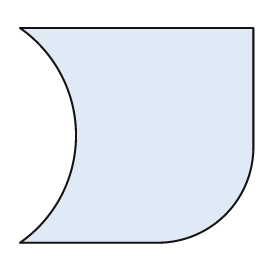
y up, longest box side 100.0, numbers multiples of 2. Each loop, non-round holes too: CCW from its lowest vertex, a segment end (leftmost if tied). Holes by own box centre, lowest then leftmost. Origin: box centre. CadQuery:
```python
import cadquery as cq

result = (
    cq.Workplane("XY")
    .moveTo(-50.0, -46.0)
    .lineTo(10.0, -46.0)
    .threePointArc((38.0, -34.0), (50.0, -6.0))
    .lineTo(50.0, 46.0)
    .lineTo(-50.0, 46.0)
    .threePointArc((-26.0, 0.0), (-50.0, -46.0))
    .close()
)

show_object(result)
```